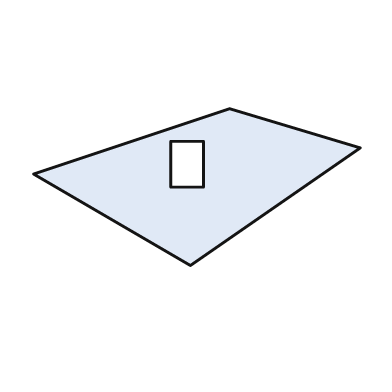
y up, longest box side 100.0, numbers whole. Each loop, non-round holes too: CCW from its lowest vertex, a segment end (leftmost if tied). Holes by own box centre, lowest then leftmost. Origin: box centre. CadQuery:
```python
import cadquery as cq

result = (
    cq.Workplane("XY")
    .moveTo(-2.0, -24.0)
    .lineTo(50.0, 12.0)
    .lineTo(10.0, 24.0)
    .lineTo(-50.0, 4.0)
    .close()
    .moveTo(-8.0, 0.0)
    .lineTo(2.0, 0.0)
    .lineTo(2.0, 14.0)
    .lineTo(-8.0, 14.0)
    .close()
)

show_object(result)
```